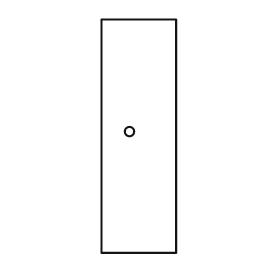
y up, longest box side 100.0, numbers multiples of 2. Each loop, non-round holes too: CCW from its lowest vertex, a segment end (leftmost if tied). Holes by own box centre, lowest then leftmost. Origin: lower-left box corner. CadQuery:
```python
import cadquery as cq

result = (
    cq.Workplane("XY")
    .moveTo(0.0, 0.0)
    .lineTo(32.0, 0.0)
    .lineTo(32.0, 100.0)
    .lineTo(0.0, 100.0)
    .close()
    .moveTo(12.0, 52.0)
    .circle(2.0)
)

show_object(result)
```